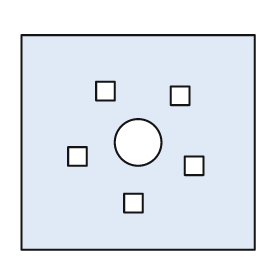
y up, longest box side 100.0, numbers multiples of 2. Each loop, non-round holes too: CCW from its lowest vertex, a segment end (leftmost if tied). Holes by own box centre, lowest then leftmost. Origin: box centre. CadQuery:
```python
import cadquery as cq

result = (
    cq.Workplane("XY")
    .moveTo(-50.0, -46.0)
    .lineTo(50.0, -46.0)
    .lineTo(50.0, 46.0)
    .lineTo(-50.0, 46.0)
    .close()
    .moveTo(-6.0, -30.0)
    .lineTo(2.0, -30.0)
    .lineTo(2.0, -22.0)
    .lineTo(-6.0, -22.0)
    .close()
    .moveTo(20.0, -14.0)
    .lineTo(28.0, -14.0)
    .lineTo(28.0, -6.0)
    .lineTo(20.0, -6.0)
    .close()
    .moveTo(-30.0, -10.0)
    .lineTo(-22.0, -10.0)
    .lineTo(-22.0, -2.0)
    .lineTo(-30.0, -2.0)
    .close()
    .moveTo(0.0, 0.0)
    .circle(10.0)
    .moveTo(14.0, 16.0)
    .lineTo(22.0, 16.0)
    .lineTo(22.0, 24.0)
    .lineTo(14.0, 24.0)
    .close()
    .moveTo(-18.0, 18.0)
    .lineTo(-10.0, 18.0)
    .lineTo(-10.0, 26.0)
    .lineTo(-18.0, 26.0)
    .close()
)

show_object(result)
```